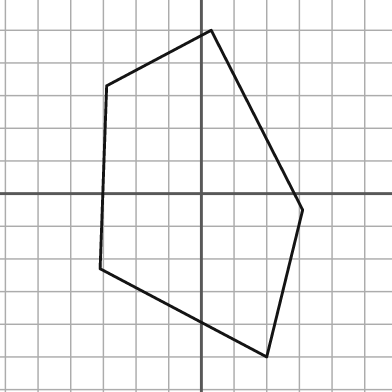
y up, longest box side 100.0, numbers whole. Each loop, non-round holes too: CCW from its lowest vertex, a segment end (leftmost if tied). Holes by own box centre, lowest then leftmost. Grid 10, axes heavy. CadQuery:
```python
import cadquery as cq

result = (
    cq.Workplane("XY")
    .moveTo(20.0, -50.0)
    .lineTo(31.0, -5.0)
    .lineTo(3.0, 50.0)
    .lineTo(-29.0, 33.0)
    .lineTo(-31.0, -23.0)
    .close()
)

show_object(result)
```